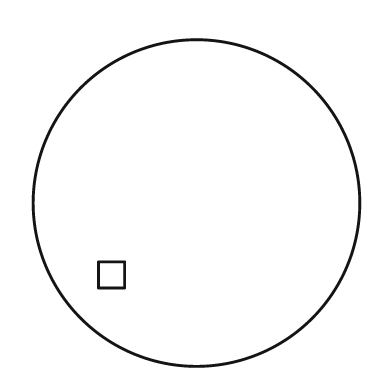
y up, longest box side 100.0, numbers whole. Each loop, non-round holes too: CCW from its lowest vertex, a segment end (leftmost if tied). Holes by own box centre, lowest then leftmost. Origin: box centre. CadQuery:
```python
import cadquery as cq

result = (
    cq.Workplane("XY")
    .moveTo(0.0, 0.0)
    .circle(50.0)
    .moveTo(-30.0, -26.0)
    .lineTo(-22.0, -26.0)
    .lineTo(-22.0, -18.0)
    .lineTo(-30.0, -18.0)
    .close()
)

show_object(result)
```